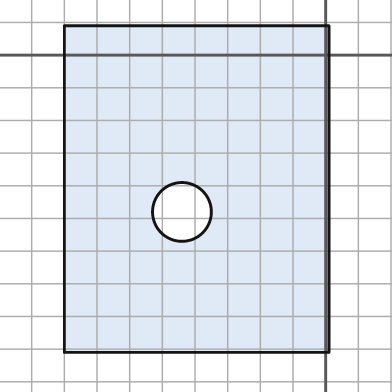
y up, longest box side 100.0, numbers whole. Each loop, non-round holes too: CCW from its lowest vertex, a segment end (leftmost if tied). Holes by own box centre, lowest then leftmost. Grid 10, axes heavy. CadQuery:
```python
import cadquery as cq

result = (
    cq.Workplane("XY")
    .moveTo(-80.0, -91.0)
    .lineTo(1.0, -91.0)
    .lineTo(1.0, 9.0)
    .lineTo(-80.0, 9.0)
    .close()
    .moveTo(-44.0, -48.0)
    .circle(9.0)
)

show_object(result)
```